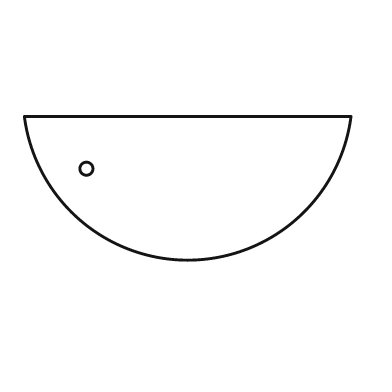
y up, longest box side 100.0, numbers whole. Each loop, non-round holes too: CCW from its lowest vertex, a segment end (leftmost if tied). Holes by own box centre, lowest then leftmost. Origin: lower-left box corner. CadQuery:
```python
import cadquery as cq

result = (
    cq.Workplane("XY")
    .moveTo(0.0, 44.0)
    .threePointArc((50.0, 0.0), (100.0, 44.0))
    .close()
    .moveTo(19.0, 28.0)
    .circle(2.0)
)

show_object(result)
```